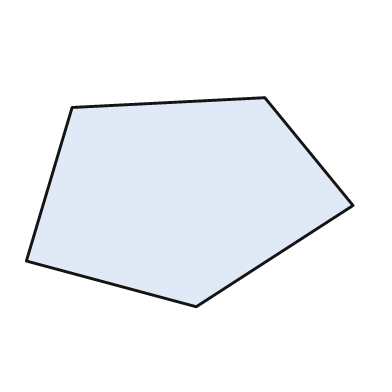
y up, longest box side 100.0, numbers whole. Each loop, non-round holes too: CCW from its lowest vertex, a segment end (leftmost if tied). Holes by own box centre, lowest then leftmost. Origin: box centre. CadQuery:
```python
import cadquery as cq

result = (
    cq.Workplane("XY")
    .moveTo(2.0, -32.0)
    .lineTo(50.0, -1.0)
    .lineTo(23.0, 32.0)
    .lineTo(-36.0, 29.0)
    .lineTo(-50.0, -18.0)
    .close()
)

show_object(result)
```